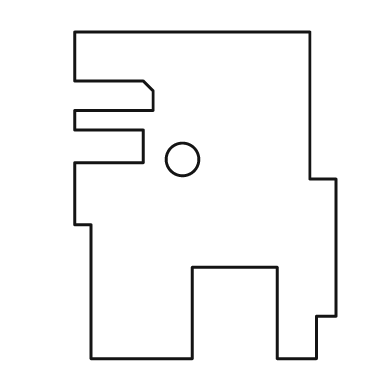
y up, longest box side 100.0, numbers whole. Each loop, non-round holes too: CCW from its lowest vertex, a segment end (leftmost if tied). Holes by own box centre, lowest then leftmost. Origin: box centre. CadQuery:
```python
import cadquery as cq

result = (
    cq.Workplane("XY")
    .moveTo(-35.0, -50.0)
    .lineTo(-4.0, -50.0)
    .lineTo(-4.0, -22.0)
    .lineTo(22.0, -22.0)
    .lineTo(22.0, -50.0)
    .lineTo(34.0, -50.0)
    .lineTo(34.0, -37.0)
    .lineTo(40.0, -37.0)
    .lineTo(40.0, 5.0)
    .lineTo(32.0, 5.0)
    .lineTo(32.0, 50.0)
    .lineTo(-40.0, 50.0)
    .lineTo(-40.0, 35.0)
    .lineTo(-19.0, 35.0)
    .lineTo(-16.0, 32.0)
    .lineTo(-16.0, 26.0)
    .lineTo(-40.0, 26.0)
    .lineTo(-40.0, 20.0)
    .lineTo(-19.0, 20.0)
    .lineTo(-19.0, 10.0)
    .lineTo(-40.0, 10.0)
    .lineTo(-40.0, -9.0)
    .lineTo(-35.0, -9.0)
    .close()
    .moveTo(-7.0, 11.0)
    .circle(5.0)
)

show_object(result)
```